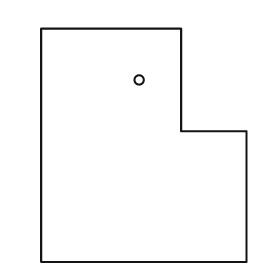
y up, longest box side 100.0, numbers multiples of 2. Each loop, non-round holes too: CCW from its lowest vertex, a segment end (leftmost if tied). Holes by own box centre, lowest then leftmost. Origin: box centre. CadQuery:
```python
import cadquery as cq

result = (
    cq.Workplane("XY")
    .moveTo(-44.0, -50.0)
    .lineTo(44.0, -50.0)
    .lineTo(44.0, 6.0)
    .lineTo(16.0, 6.0)
    .lineTo(16.0, 50.0)
    .lineTo(-44.0, 50.0)
    .close()
    .moveTo(-2.0, 28.0)
    .circle(2.0)
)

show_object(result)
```